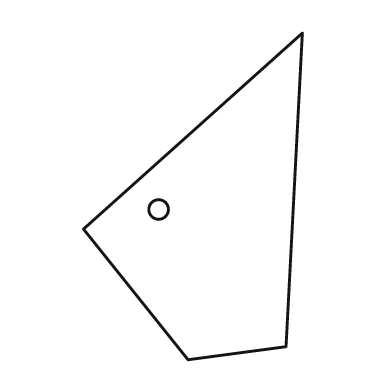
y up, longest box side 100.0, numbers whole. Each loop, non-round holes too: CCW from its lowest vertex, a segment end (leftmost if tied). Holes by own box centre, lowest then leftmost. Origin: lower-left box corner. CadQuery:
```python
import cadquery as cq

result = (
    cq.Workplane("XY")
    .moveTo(32.0, 0.0)
    .lineTo(62.0, 4.0)
    .lineTo(67.0, 100.0)
    .lineTo(0.0, 40.0)
    .close()
    .moveTo(23.0, 46.0)
    .circle(3.0)
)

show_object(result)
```